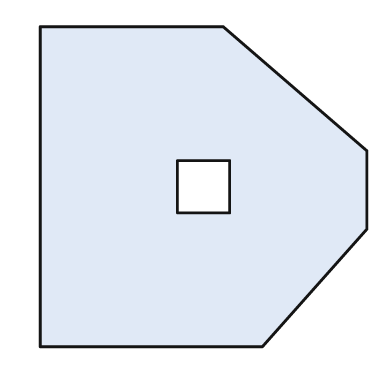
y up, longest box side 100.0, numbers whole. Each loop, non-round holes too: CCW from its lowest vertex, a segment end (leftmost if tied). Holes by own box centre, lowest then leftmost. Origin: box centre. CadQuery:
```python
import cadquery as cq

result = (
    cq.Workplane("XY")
    .moveTo(-50.0, -49.0)
    .lineTo(18.0, -49.0)
    .lineTo(50.0, -13.0)
    .lineTo(50.0, 11.0)
    .lineTo(6.0, 49.0)
    .lineTo(-50.0, 49.0)
    .close()
    .moveTo(-8.0, -8.0)
    .lineTo(8.0, -8.0)
    .lineTo(8.0, 8.0)
    .lineTo(-8.0, 8.0)
    .close()
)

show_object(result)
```